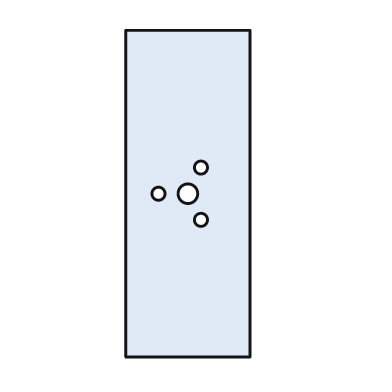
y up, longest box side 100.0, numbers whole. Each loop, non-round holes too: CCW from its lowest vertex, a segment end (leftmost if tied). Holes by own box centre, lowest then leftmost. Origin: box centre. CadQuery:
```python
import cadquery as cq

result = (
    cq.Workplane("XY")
    .moveTo(-19.0, -50.0)
    .lineTo(19.0, -50.0)
    .lineTo(19.0, 50.0)
    .lineTo(-19.0, 50.0)
    .close()
    .moveTo(4.0, -8.0)
    .circle(2.0)
    .moveTo(-9.0, 0.0)
    .circle(2.0)
    .moveTo(0.0, 0.0)
    .circle(3.0)
    .moveTo(4.0, 8.0)
    .circle(2.0)
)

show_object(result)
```